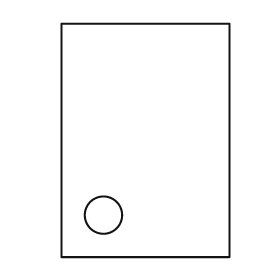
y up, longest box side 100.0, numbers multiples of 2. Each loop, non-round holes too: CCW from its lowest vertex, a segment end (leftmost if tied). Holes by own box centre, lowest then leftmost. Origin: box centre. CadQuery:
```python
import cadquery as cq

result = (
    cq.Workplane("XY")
    .moveTo(-36.0, -50.0)
    .lineTo(36.0, -50.0)
    .lineTo(36.0, 50.0)
    .lineTo(-36.0, 50.0)
    .close()
    .moveTo(-18.0, -32.0)
    .circle(8.0)
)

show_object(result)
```